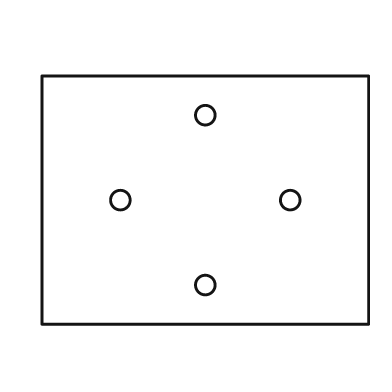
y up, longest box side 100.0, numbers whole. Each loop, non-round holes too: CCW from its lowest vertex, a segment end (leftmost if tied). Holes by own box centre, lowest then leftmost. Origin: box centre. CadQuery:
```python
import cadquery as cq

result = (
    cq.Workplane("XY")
    .moveTo(-50.0, -38.0)
    .lineTo(50.0, -38.0)
    .lineTo(50.0, 38.0)
    .lineTo(-50.0, 38.0)
    .close()
    .moveTo(0.0, -26.0)
    .circle(3.0)
    .moveTo(-26.0, 0.0)
    .circle(3.0)
    .moveTo(26.0, 0.0)
    .circle(3.0)
    .moveTo(0.0, 26.0)
    .circle(3.0)
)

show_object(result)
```